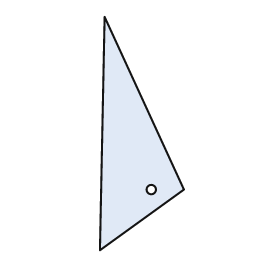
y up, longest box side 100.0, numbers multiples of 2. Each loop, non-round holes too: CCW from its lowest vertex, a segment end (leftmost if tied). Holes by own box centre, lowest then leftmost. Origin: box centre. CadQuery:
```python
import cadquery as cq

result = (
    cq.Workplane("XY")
    .moveTo(-18.0, -50.0)
    .lineTo(18.0, -24.0)
    .lineTo(-16.0, 50.0)
    .close()
    .moveTo(4.0, -24.0)
    .circle(2.0)
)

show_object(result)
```